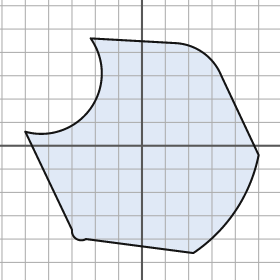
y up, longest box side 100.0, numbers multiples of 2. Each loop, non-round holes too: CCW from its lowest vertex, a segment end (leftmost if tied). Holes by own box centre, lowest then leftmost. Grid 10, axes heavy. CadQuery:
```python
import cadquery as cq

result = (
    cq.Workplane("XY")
    .moveTo(22.0, -46.0)
    .threePointArc((40.0, -28.0), (50.0, -4.0))
    .lineTo(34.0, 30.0)
    .threePointArc((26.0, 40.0), (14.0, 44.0))
    .lineTo(-22.0, 46.0)
    .threePointArc((-22.0, 16.0), (-50.0, 6.0))
    .lineTo(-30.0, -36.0)
    .threePointArc((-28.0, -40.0), (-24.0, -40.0))
    .close()
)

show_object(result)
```